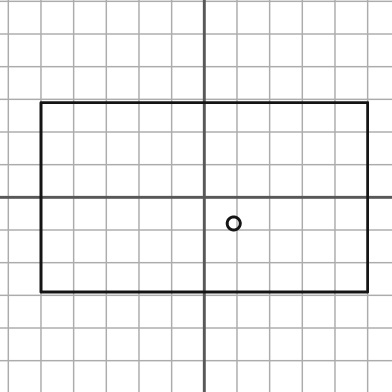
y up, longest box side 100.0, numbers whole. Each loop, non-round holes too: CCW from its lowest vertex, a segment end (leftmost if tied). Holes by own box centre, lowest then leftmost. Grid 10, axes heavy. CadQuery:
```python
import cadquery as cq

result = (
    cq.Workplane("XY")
    .moveTo(-50.0, -29.0)
    .lineTo(50.0, -29.0)
    .lineTo(50.0, 29.0)
    .lineTo(-50.0, 29.0)
    .close()
    .moveTo(9.0, -8.0)
    .circle(2.0)
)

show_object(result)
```